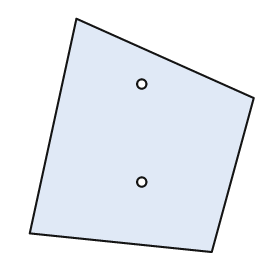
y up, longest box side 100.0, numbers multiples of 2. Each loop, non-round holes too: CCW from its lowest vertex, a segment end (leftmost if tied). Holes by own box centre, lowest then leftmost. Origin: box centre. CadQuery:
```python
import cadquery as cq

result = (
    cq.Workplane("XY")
    .moveTo(30.0, -50.0)
    .lineTo(48.0, 16.0)
    .lineTo(-28.0, 50.0)
    .lineTo(-48.0, -42.0)
    .close()
    .moveTo(0.0, -20.0)
    .circle(2.0)
    .moveTo(0.0, 22.0)
    .circle(2.0)
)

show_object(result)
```